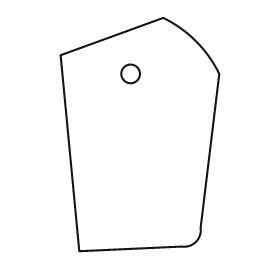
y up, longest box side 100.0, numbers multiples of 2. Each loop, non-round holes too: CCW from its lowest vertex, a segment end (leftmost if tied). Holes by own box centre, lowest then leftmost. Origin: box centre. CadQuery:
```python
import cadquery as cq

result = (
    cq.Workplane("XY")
    .moveTo(-26.0, -50.0)
    .lineTo(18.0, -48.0)
    .threePointArc((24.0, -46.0), (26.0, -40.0))
    .lineTo(34.0, 26.0)
    .threePointArc((24.0, 40.0), (10.0, 50.0))
    .lineTo(-34.0, 34.0)
    .close()
    .moveTo(-4.0, 26.0)
    .circle(4.0)
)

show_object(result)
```